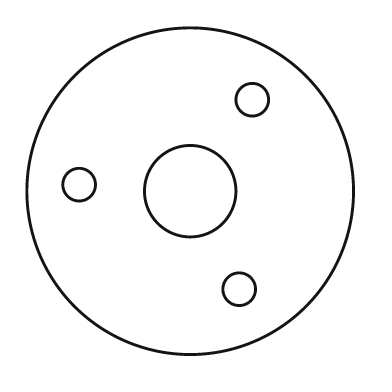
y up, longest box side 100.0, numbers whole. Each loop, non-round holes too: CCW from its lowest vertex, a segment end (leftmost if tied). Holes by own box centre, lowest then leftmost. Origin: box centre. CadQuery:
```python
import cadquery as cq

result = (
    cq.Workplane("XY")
    .moveTo(0.0, 0.0)
    .circle(50.0)
    .moveTo(15.0, -30.0)
    .circle(5.0)
    .moveTo(0.0, 0.0)
    .circle(14.0)
    .moveTo(-34.0, 2.0)
    .circle(5.0)
    .moveTo(19.0, 28.0)
    .circle(5.0)
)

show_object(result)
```